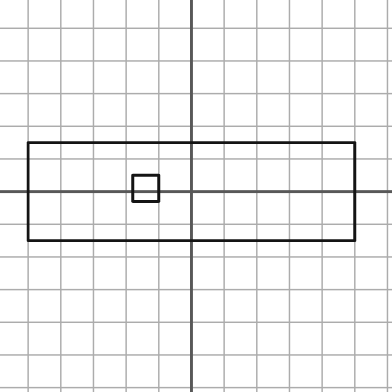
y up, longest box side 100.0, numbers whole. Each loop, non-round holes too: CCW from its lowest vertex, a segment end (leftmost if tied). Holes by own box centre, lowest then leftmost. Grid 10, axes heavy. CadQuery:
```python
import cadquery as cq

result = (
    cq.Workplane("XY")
    .moveTo(-50.0, -15.0)
    .lineTo(50.0, -15.0)
    .lineTo(50.0, 15.0)
    .lineTo(-50.0, 15.0)
    .close()
    .moveTo(-18.0, -3.0)
    .lineTo(-10.0, -3.0)
    .lineTo(-10.0, 5.0)
    .lineTo(-18.0, 5.0)
    .close()
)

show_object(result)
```